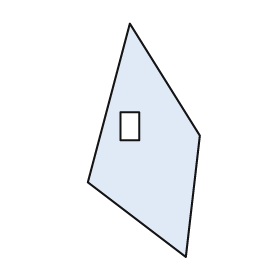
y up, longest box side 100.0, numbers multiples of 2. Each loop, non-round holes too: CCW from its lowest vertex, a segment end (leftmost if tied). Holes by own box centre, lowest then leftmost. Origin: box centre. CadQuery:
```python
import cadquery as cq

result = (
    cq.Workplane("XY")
    .moveTo(18.0, -50.0)
    .lineTo(24.0, 2.0)
    .lineTo(-6.0, 50.0)
    .lineTo(-24.0, -18.0)
    .close()
    .moveTo(-10.0, 0.0)
    .lineTo(-2.0, 0.0)
    .lineTo(-2.0, 12.0)
    .lineTo(-10.0, 12.0)
    .close()
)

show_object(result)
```